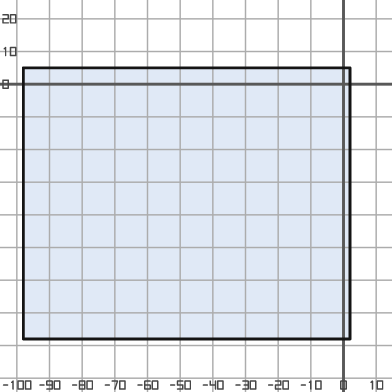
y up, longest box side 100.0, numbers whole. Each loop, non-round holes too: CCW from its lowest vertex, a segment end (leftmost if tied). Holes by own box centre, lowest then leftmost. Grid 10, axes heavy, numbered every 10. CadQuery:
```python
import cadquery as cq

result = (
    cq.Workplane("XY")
    .moveTo(-98.0, -78.0)
    .lineTo(2.0, -78.0)
    .lineTo(2.0, 5.0)
    .lineTo(-98.0, 5.0)
    .close()
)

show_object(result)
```